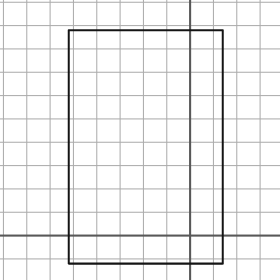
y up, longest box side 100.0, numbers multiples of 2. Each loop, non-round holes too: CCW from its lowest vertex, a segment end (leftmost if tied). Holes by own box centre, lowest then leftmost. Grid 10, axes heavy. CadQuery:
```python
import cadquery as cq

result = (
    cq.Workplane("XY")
    .moveTo(-52.0, -12.0)
    .lineTo(14.0, -12.0)
    .lineTo(14.0, 88.0)
    .lineTo(-52.0, 88.0)
    .close()
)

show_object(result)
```